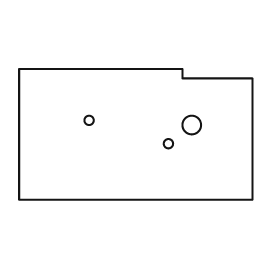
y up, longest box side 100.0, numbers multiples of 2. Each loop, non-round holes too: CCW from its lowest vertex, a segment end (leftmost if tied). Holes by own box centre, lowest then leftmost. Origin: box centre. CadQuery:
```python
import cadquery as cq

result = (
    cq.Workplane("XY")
    .moveTo(-50.0, -28.0)
    .lineTo(50.0, -28.0)
    .lineTo(50.0, 24.0)
    .lineTo(20.0, 24.0)
    .lineTo(20.0, 28.0)
    .lineTo(-50.0, 28.0)
    .close()
    .moveTo(14.0, -4.0)
    .circle(2.0)
    .moveTo(24.0, 4.0)
    .circle(4.0)
    .moveTo(-20.0, 6.0)
    .circle(2.0)
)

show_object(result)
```